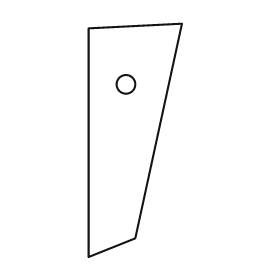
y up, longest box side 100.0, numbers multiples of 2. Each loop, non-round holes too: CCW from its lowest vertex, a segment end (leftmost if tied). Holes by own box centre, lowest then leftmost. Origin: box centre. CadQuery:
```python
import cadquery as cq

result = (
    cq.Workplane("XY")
    .moveTo(-20.0, -50.0)
    .lineTo(0.0, -42.0)
    .lineTo(20.0, 50.0)
    .lineTo(-20.0, 48.0)
    .close()
    .moveTo(-4.0, 24.0)
    .circle(4.0)
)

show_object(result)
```